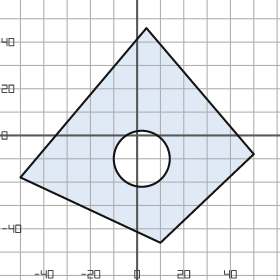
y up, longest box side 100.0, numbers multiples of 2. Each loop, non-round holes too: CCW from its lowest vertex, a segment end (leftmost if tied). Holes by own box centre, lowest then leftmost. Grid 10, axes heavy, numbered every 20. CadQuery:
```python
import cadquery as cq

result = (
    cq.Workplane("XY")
    .moveTo(10.0, -46.0)
    .lineTo(50.0, -8.0)
    .lineTo(4.0, 46.0)
    .lineTo(-50.0, -18.0)
    .close()
    .moveTo(2.0, -10.0)
    .circle(12.0)
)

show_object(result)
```